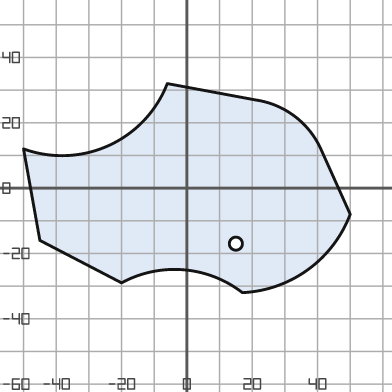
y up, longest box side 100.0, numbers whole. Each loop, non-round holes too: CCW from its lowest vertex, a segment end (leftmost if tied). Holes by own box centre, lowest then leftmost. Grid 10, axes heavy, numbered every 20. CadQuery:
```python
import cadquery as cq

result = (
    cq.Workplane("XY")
    .moveTo(17.0, -32.0)
    .threePointArc((37.0, -25.0), (50.0, -8.0))
    .lineTo(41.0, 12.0)
    .threePointArc((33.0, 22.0), (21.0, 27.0))
    .lineTo(-6.0, 32.0)
    .threePointArc((-24.0, 13.0), (-50.0, 12.0))
    .lineTo(-45.0, -16.0)
    .lineTo(-20.0, -29.0)
    .threePointArc((-1.0, -25.0), (17.0, -32.0))
    .close()
    .moveTo(15.0, -17.0)
    .circle(2.0)
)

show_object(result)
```